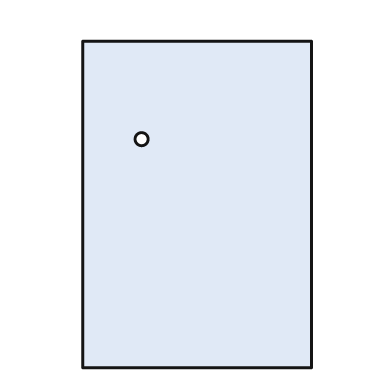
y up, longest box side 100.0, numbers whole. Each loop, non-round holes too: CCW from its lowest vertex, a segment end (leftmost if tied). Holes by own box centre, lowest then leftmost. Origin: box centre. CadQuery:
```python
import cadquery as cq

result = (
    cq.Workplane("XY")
    .moveTo(-35.0, -50.0)
    .lineTo(35.0, -50.0)
    .lineTo(35.0, 50.0)
    .lineTo(-35.0, 50.0)
    .close()
    .moveTo(-17.0, 20.0)
    .circle(2.0)
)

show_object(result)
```